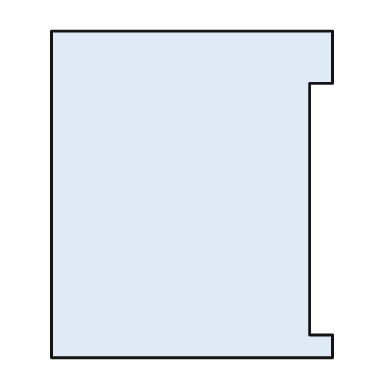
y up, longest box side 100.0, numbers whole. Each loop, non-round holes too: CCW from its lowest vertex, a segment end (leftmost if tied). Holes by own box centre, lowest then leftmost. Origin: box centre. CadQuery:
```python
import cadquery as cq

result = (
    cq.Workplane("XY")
    .moveTo(-43.0, -50.0)
    .lineTo(43.0, -50.0)
    .lineTo(43.0, -43.0)
    .lineTo(36.0, -43.0)
    .lineTo(36.0, 34.0)
    .lineTo(43.0, 34.0)
    .lineTo(43.0, 50.0)
    .lineTo(-43.0, 50.0)
    .close()
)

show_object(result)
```